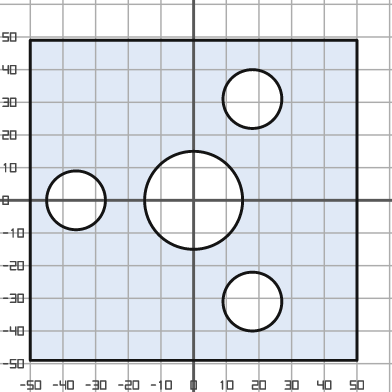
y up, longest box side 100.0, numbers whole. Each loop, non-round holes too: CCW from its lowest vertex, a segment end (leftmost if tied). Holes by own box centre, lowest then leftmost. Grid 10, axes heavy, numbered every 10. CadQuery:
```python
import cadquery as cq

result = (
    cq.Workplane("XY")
    .moveTo(-50.0, -49.0)
    .lineTo(50.0, -49.0)
    .lineTo(50.0, 49.0)
    .lineTo(-50.0, 49.0)
    .close()
    .moveTo(18.0, -31.0)
    .circle(9.0)
    .moveTo(-36.0, 0.0)
    .circle(9.0)
    .moveTo(0.0, 0.0)
    .circle(15.0)
    .moveTo(18.0, 31.0)
    .circle(9.0)
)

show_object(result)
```